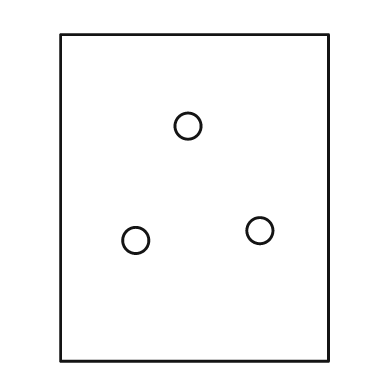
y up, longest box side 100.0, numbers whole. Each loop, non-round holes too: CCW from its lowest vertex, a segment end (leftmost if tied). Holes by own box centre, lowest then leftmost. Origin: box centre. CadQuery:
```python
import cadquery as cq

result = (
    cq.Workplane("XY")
    .moveTo(-41.0, -50.0)
    .lineTo(41.0, -50.0)
    .lineTo(41.0, 50.0)
    .lineTo(-41.0, 50.0)
    .close()
    .moveTo(-18.0, -13.0)
    .circle(4.0)
    .moveTo(20.0, -10.0)
    .circle(4.0)
    .moveTo(-2.0, 22.0)
    .circle(4.0)
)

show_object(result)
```